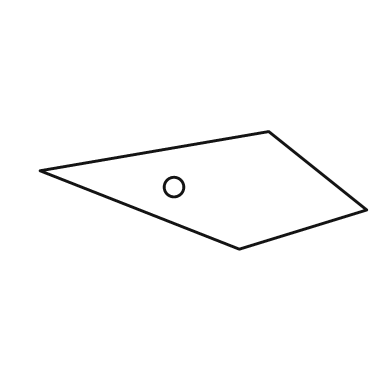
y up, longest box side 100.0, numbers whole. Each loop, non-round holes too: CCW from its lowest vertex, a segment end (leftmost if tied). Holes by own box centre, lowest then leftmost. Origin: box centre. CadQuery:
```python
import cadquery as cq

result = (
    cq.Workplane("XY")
    .moveTo(11.0, -18.0)
    .lineTo(50.0, -6.0)
    .lineTo(20.0, 18.0)
    .lineTo(-50.0, 6.0)
    .close()
    .moveTo(-9.0, 1.0)
    .circle(3.0)
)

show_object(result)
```